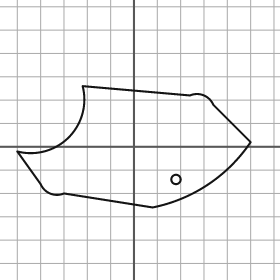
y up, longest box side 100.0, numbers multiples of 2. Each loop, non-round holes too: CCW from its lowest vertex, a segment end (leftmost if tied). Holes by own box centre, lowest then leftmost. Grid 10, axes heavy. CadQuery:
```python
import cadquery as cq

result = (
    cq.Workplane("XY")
    .moveTo(8.0, -26.0)
    .threePointArc((32.0, -16.0), (50.0, 2.0))
    .lineTo(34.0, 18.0)
    .threePointArc((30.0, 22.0), (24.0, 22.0))
    .lineTo(-22.0, 26.0)
    .threePointArc((-28.0, 4.0), (-50.0, -2.0))
    .lineTo(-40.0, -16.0)
    .threePointArc((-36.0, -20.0), (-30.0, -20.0))
    .close()
    .moveTo(18.0, -14.0)
    .circle(2.0)
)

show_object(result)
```